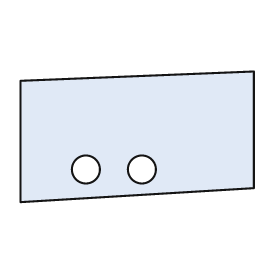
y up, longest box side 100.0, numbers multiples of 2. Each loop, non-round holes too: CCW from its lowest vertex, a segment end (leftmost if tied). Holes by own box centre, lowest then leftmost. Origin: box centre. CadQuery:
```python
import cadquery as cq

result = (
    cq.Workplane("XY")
    .moveTo(-50.0, -28.0)
    .lineTo(50.0, -22.0)
    .lineTo(50.0, 28.0)
    .lineTo(-50.0, 24.0)
    .close()
    .moveTo(-22.0, -14.0)
    .circle(6.0)
    .moveTo(2.0, -14.0)
    .circle(6.0)
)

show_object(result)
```